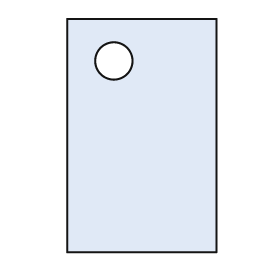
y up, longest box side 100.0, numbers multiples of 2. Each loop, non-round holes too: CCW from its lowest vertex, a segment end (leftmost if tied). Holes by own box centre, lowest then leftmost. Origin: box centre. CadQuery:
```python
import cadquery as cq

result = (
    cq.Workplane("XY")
    .moveTo(-32.0, -50.0)
    .lineTo(32.0, -50.0)
    .lineTo(32.0, 50.0)
    .lineTo(-32.0, 50.0)
    .close()
    .moveTo(-12.0, 32.0)
    .circle(8.0)
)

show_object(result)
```